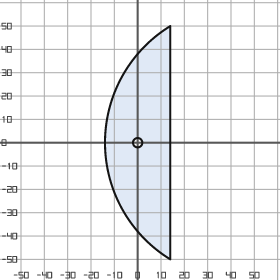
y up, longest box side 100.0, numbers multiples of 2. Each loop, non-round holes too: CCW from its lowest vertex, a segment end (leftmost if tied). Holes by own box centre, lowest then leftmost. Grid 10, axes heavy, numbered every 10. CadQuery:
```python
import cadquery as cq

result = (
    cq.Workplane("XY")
    .moveTo(14.0, -50.0)
    .lineTo(14.0, 50.0)
    .threePointArc((-14.0, 0.0), (14.0, -50.0))
    .close()
    .moveTo(0.0, 0.0)
    .circle(2.0)
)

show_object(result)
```